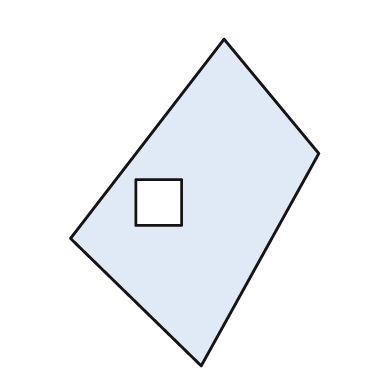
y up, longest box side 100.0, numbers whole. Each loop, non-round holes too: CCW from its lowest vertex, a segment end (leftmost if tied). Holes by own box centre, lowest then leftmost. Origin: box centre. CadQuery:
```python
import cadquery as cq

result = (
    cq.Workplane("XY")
    .moveTo(2.0, -50.0)
    .lineTo(38.0, 15.0)
    .lineTo(9.0, 50.0)
    .lineTo(-38.0, -11.0)
    .close()
    .moveTo(-18.0, -7.0)
    .lineTo(-4.0, -7.0)
    .lineTo(-4.0, 7.0)
    .lineTo(-18.0, 7.0)
    .close()
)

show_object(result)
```